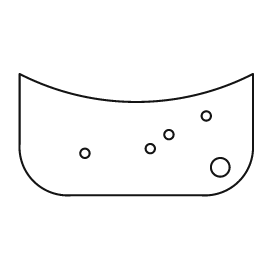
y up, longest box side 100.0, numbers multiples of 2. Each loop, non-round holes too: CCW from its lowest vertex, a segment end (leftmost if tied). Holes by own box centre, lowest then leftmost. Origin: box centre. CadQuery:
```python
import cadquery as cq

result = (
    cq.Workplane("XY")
    .moveTo(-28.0, -26.0)
    .lineTo(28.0, -26.0)
    .threePointArc((44.0, -20.0), (50.0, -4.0))
    .lineTo(50.0, 26.0)
    .threePointArc((0.0, 14.0), (-50.0, 26.0))
    .lineTo(-50.0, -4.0)
    .threePointArc((-44.0, -20.0), (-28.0, -26.0))
    .close()
    .moveTo(36.0, -14.0)
    .circle(4.0)
    .moveTo(-22.0, -8.0)
    .circle(2.0)
    .moveTo(6.0, -6.0)
    .circle(2.0)
    .moveTo(14.0, 0.0)
    .circle(2.0)
    .moveTo(30.0, 8.0)
    .circle(2.0)
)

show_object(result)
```